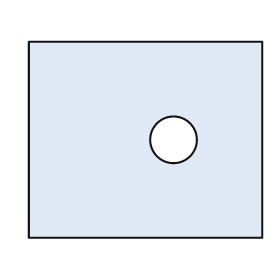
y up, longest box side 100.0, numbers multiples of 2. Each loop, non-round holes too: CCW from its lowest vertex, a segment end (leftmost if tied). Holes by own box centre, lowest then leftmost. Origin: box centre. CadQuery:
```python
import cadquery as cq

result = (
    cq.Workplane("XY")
    .moveTo(-50.0, -42.0)
    .lineTo(50.0, -42.0)
    .lineTo(50.0, 42.0)
    .lineTo(-50.0, 42.0)
    .close()
    .moveTo(12.0, 0.0)
    .circle(10.0)
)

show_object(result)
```